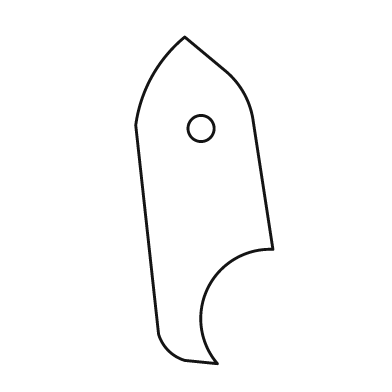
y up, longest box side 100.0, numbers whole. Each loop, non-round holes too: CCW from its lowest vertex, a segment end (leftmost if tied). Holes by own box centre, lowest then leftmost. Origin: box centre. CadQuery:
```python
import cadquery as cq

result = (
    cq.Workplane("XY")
    .moveTo(4.0, -50.0)
    .threePointArc((1.0, -27.0), (21.0, -15.0))
    .lineTo(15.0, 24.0)
    .threePointArc((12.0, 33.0), (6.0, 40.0))
    .lineTo(-6.0, 50.0)
    .threePointArc((-16.0, 38.0), (-21.0, 23.0))
    .lineTo(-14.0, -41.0)
    .threePointArc((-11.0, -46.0), (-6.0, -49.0))
    .close()
    .moveTo(-1.0, 22.0)
    .circle(4.0)
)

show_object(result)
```